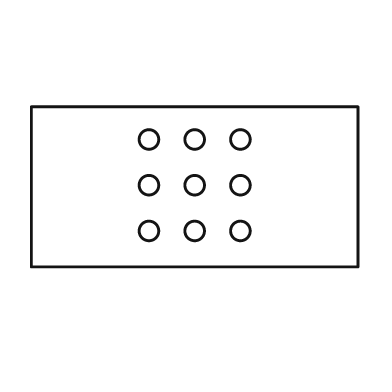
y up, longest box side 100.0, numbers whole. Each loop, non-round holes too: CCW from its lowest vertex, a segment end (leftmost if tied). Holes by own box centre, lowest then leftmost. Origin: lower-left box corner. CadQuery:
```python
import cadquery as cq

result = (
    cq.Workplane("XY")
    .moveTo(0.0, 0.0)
    .lineTo(100.0, 0.0)
    .lineTo(100.0, 49.0)
    .lineTo(0.0, 49.0)
    .close()
    .moveTo(36.0, 11.0)
    .circle(3.0)
    .moveTo(50.0, 11.0)
    .circle(3.0)
    .moveTo(64.0, 11.0)
    .circle(3.0)
    .moveTo(36.0, 25.0)
    .circle(3.0)
    .moveTo(50.0, 25.0)
    .circle(3.0)
    .moveTo(64.0, 25.0)
    .circle(3.0)
    .moveTo(36.0, 39.0)
    .circle(3.0)
    .moveTo(50.0, 39.0)
    .circle(3.0)
    .moveTo(64.0, 39.0)
    .circle(3.0)
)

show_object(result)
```